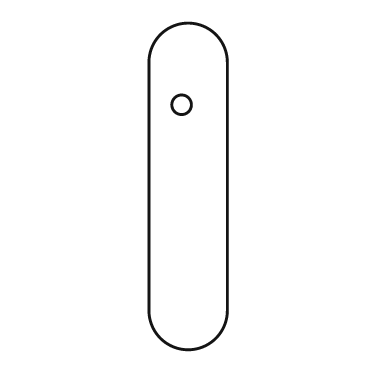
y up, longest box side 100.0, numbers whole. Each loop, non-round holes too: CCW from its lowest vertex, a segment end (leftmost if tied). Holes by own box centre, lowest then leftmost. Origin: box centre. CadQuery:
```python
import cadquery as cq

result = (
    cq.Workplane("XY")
    .moveTo(-12.0, -38.0)
    .threePointArc((0.0, -50.0), (12.0, -38.0))
    .lineTo(12.0, 38.0)
    .threePointArc((0.0, 50.0), (-12.0, 38.0))
    .close()
    .moveTo(-2.0, 25.0)
    .circle(3.0)
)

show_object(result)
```